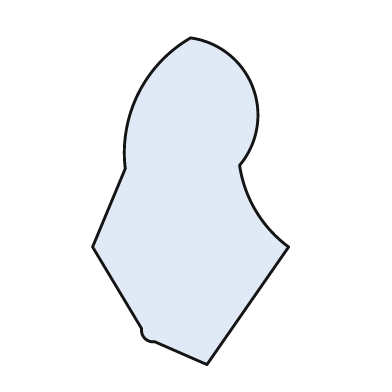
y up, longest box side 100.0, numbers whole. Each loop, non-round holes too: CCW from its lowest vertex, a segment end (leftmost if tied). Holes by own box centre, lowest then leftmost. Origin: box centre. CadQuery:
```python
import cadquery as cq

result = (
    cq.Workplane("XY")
    .moveTo(5.0, -50.0)
    .lineTo(30.0, -14.0)
    .threePointArc((20.0, -3.0), (15.0, 11.0))
    .threePointArc((19.0, 35.0), (0.0, 50.0))
    .threePointArc((-16.0, 33.0), (-20.0, 10.0))
    .lineTo(-30.0, -14.0)
    .lineTo(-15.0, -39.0)
    .threePointArc((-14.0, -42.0), (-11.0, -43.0))
    .close()
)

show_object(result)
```